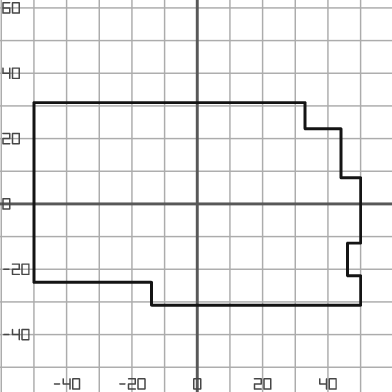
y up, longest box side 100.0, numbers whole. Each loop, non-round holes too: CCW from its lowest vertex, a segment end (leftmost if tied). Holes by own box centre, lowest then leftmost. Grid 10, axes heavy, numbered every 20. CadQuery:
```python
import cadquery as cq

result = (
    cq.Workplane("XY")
    .moveTo(-14.0, -31.0)
    .lineTo(50.0, -31.0)
    .lineTo(50.0, -22.0)
    .lineTo(46.0, -22.0)
    .lineTo(46.0, -12.0)
    .lineTo(50.0, -12.0)
    .lineTo(50.0, 8.0)
    .lineTo(44.0, 8.0)
    .lineTo(44.0, 23.0)
    .lineTo(33.0, 23.0)
    .lineTo(33.0, 31.0)
    .lineTo(-50.0, 31.0)
    .lineTo(-50.0, -24.0)
    .lineTo(-14.0, -24.0)
    .close()
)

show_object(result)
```